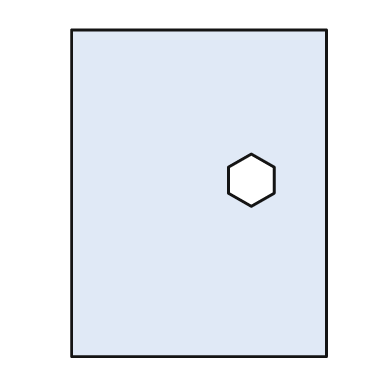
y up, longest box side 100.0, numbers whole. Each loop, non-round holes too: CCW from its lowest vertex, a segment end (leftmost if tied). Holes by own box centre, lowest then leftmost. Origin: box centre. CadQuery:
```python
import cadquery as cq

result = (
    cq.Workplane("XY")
    .moveTo(-39.0, -50.0)
    .lineTo(39.0, -50.0)
    .lineTo(39.0, 50.0)
    .lineTo(-39.0, 50.0)
    .close()
    .moveTo(16.0, -4.0)
    .lineTo(23.0, 0.0)
    .lineTo(23.0, 8.0)
    .lineTo(16.0, 12.0)
    .lineTo(9.0, 8.0)
    .lineTo(9.0, 0.0)
    .close()
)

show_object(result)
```